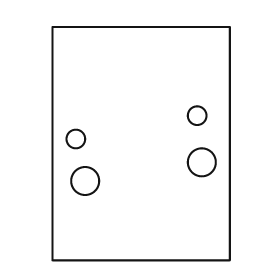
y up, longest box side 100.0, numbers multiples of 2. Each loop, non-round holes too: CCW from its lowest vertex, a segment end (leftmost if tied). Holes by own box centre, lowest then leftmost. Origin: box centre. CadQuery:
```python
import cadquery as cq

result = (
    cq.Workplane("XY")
    .moveTo(-38.0, -50.0)
    .lineTo(38.0, -50.0)
    .lineTo(38.0, 50.0)
    .lineTo(-38.0, 50.0)
    .close()
    .moveTo(-24.0, -16.0)
    .circle(6.0)
    .moveTo(26.0, -8.0)
    .circle(6.0)
    .moveTo(-28.0, 2.0)
    .circle(4.0)
    .moveTo(24.0, 12.0)
    .circle(4.0)
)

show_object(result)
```